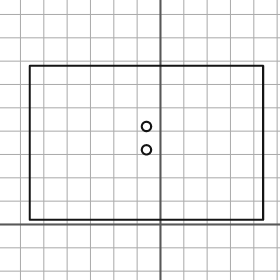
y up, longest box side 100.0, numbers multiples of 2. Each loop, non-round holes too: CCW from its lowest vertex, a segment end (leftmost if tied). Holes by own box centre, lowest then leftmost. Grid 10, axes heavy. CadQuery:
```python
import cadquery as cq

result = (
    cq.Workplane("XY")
    .moveTo(-56.0, 2.0)
    .lineTo(44.0, 2.0)
    .lineTo(44.0, 68.0)
    .lineTo(-56.0, 68.0)
    .close()
    .moveTo(-6.0, 32.0)
    .circle(2.0)
    .moveTo(-6.0, 42.0)
    .circle(2.0)
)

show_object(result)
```